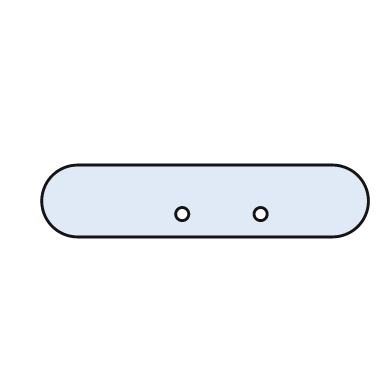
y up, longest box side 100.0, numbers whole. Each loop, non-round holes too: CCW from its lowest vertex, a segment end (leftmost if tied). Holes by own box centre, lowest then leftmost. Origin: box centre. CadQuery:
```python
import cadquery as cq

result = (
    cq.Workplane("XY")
    .moveTo(-39.0, -11.0)
    .lineTo(39.0, -11.0)
    .threePointArc((50.0, 0.0), (39.0, 11.0))
    .lineTo(-39.0, 11.0)
    .threePointArc((-50.0, 0.0), (-39.0, -11.0))
    .close()
    .moveTo(-7.0, -4.0)
    .circle(2.0)
    .moveTo(17.0, -4.0)
    .circle(2.0)
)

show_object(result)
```